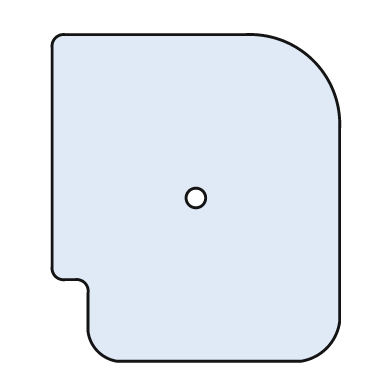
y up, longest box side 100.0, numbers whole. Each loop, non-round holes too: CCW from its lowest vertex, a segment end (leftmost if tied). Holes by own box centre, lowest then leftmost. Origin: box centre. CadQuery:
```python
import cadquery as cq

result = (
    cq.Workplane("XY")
    .moveTo(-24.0, -50.0)
    .lineTo(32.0, -50.0)
    .threePointArc((40.0, -46.0), (44.0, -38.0))
    .lineTo(44.0, 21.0)
    .threePointArc((36.0, 42.0), (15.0, 50.0))
    .lineTo(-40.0, 50.0)
    .threePointArc((-43.0, 49.0), (-44.0, 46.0))
    .lineTo(-44.0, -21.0)
    .threePointArc((-43.0, -24.0), (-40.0, -25.0))
    .lineTo(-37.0, -25.0)
    .threePointArc((-34.0, -26.0), (-33.0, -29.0))
    .lineTo(-33.0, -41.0)
    .threePointArc((-30.0, -47.0), (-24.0, -50.0))
    .close()
    .moveTo(0.0, 0.0)
    .circle(3.0)
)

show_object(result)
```